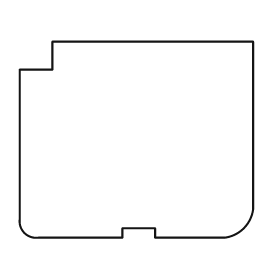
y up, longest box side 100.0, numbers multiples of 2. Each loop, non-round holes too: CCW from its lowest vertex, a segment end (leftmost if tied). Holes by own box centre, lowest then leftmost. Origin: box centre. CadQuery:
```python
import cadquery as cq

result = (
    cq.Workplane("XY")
    .moveTo(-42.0, -42.0)
    .lineTo(-6.0, -42.0)
    .lineTo(-6.0, -38.0)
    .lineTo(8.0, -38.0)
    .lineTo(8.0, -42.0)
    .lineTo(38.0, -42.0)
    .threePointArc((46.0, -38.0), (50.0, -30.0))
    .lineTo(50.0, 42.0)
    .lineTo(-36.0, 42.0)
    .lineTo(-36.0, 30.0)
    .lineTo(-50.0, 30.0)
    .lineTo(-50.0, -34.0)
    .threePointArc((-48.0, -40.0), (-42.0, -42.0))
    .close()
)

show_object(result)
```